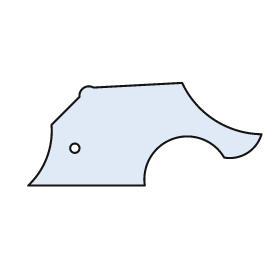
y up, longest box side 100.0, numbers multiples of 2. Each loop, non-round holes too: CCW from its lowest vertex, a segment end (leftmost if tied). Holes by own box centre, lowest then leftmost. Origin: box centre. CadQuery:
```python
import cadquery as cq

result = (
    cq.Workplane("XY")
    .moveTo(-50.0, -22.0)
    .lineTo(0.0, -22.0)
    .threePointArc((12.0, -2.0), (34.0, -10.0))
    .threePointArc((44.0, -8.0), (50.0, 0.0))
    .threePointArc((30.0, 6.0), (16.0, 22.0))
    .lineTo(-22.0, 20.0)
    .threePointArc((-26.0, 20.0), (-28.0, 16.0))
    .lineTo(-40.0, 4.0)
    .threePointArc((-42.0, -10.0), (-50.0, -22.0))
    .close()
    .moveTo(-30.0, -6.0)
    .circle(2.0)
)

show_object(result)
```